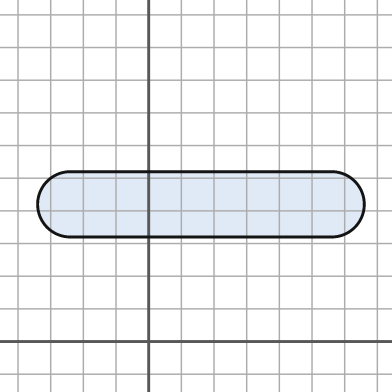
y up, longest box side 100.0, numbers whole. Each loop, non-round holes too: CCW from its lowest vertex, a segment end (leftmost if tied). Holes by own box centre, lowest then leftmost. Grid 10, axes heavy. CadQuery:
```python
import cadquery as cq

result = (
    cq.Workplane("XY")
    .moveTo(-24.0, 32.0)
    .lineTo(56.0, 32.0)
    .threePointArc((66.0, 42.0), (56.0, 52.0))
    .lineTo(-24.0, 52.0)
    .threePointArc((-34.0, 42.0), (-24.0, 32.0))
    .close()
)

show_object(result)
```